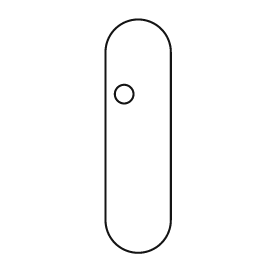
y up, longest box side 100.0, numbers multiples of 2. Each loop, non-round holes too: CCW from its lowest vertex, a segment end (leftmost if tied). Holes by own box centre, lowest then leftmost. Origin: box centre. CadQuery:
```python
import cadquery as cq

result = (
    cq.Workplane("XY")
    .moveTo(-14.0, -36.0)
    .threePointArc((0.0, -50.0), (14.0, -36.0))
    .lineTo(14.0, 36.0)
    .threePointArc((0.0, 50.0), (-14.0, 36.0))
    .close()
    .moveTo(-6.0, 18.0)
    .circle(4.0)
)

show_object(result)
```